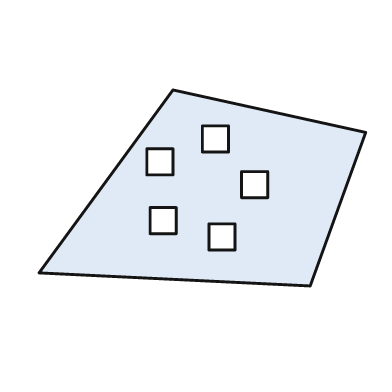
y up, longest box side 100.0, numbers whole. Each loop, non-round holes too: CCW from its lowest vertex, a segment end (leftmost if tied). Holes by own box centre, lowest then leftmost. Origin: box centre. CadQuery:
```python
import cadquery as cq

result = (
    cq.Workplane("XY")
    .moveTo(33.0, -30.0)
    .lineTo(50.0, 17.0)
    .lineTo(-9.0, 30.0)
    .lineTo(-50.0, -26.0)
    .close()
    .moveTo(2.0, -19.0)
    .lineTo(10.0, -19.0)
    .lineTo(10.0, -11.0)
    .lineTo(2.0, -11.0)
    .close()
    .moveTo(-16.0, -14.0)
    .lineTo(-8.0, -14.0)
    .lineTo(-8.0, -6.0)
    .lineTo(-16.0, -6.0)
    .close()
    .moveTo(12.0, -3.0)
    .lineTo(20.0, -3.0)
    .lineTo(20.0, 5.0)
    .lineTo(12.0, 5.0)
    .close()
    .moveTo(-17.0, 4.0)
    .lineTo(-9.0, 4.0)
    .lineTo(-9.0, 12.0)
    .lineTo(-17.0, 12.0)
    .close()
    .moveTo(0.0, 11.0)
    .lineTo(8.0, 11.0)
    .lineTo(8.0, 19.0)
    .lineTo(0.0, 19.0)
    .close()
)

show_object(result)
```